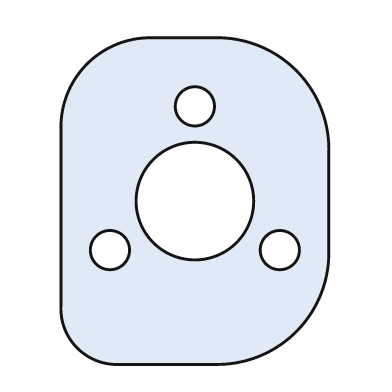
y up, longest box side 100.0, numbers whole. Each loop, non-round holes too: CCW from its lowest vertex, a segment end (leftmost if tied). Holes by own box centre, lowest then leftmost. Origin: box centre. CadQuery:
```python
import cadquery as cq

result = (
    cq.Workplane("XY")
    .moveTo(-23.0, -50.0)
    .lineTo(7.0, -50.0)
    .threePointArc((31.0, -40.0), (41.0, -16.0))
    .lineTo(41.0, 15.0)
    .threePointArc((31.0, 40.0), (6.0, 50.0))
    .lineTo(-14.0, 50.0)
    .threePointArc((-33.0, 42.0), (-41.0, 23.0))
    .lineTo(-41.0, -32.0)
    .threePointArc((-36.0, -45.0), (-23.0, -50.0))
    .close()
    .moveTo(-26.0, -15.0)
    .circle(6.0)
    .moveTo(26.0, -15.0)
    .circle(6.0)
    .moveTo(0.0, 0.0)
    .circle(18.0)
    .moveTo(0.0, 29.0)
    .circle(6.0)
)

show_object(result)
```